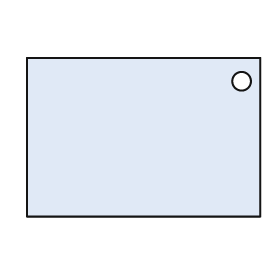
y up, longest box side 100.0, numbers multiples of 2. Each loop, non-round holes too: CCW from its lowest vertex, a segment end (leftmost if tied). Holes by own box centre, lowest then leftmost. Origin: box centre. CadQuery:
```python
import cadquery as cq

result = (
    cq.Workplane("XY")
    .moveTo(-50.0, -34.0)
    .lineTo(50.0, -34.0)
    .lineTo(50.0, 34.0)
    .lineTo(-50.0, 34.0)
    .close()
    .moveTo(42.0, 24.0)
    .circle(4.0)
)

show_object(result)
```